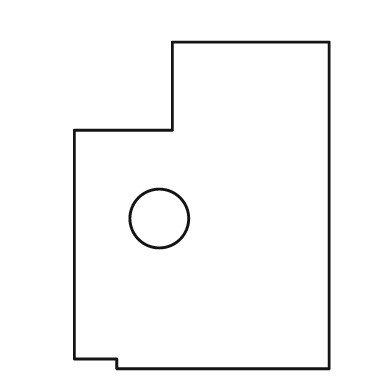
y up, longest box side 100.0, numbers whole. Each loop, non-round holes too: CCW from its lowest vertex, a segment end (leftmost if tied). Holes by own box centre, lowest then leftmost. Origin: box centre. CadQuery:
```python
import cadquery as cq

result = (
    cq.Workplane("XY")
    .moveTo(-26.0, -50.0)
    .lineTo(39.0, -50.0)
    .lineTo(39.0, 50.0)
    .lineTo(-9.0, 50.0)
    .lineTo(-9.0, 23.0)
    .lineTo(-39.0, 23.0)
    .lineTo(-39.0, -47.0)
    .lineTo(-26.0, -47.0)
    .close()
    .moveTo(-13.0, -4.0)
    .circle(9.0)
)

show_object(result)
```